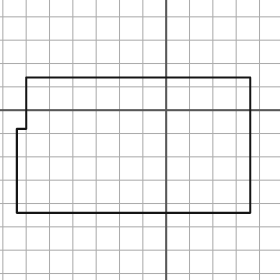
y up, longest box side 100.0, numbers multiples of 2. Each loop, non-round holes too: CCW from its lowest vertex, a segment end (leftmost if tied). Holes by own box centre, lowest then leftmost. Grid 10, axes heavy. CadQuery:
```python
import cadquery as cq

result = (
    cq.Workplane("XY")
    .moveTo(-64.0, -44.0)
    .lineTo(36.0, -44.0)
    .lineTo(36.0, 14.0)
    .lineTo(-60.0, 14.0)
    .lineTo(-60.0, -8.0)
    .lineTo(-64.0, -8.0)
    .close()
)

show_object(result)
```